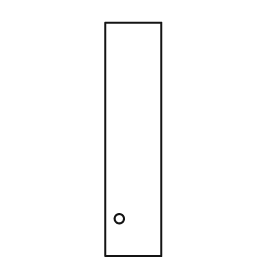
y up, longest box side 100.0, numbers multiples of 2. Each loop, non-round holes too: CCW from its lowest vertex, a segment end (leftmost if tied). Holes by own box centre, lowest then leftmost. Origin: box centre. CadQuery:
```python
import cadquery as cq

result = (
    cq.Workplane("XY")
    .moveTo(-12.0, -50.0)
    .lineTo(12.0, -50.0)
    .lineTo(12.0, 50.0)
    .lineTo(-12.0, 50.0)
    .close()
    .moveTo(-6.0, -34.0)
    .circle(2.0)
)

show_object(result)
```